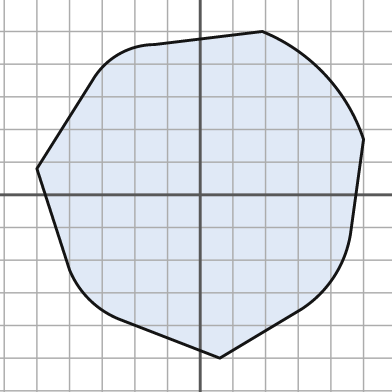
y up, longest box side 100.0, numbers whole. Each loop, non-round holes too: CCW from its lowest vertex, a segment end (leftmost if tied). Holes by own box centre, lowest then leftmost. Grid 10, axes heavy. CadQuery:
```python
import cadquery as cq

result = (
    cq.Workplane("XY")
    .moveTo(6.0, -50.0)
    .lineTo(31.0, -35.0)
    .threePointArc((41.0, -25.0), (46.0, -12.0))
    .lineTo(50.0, 17.0)
    .threePointArc((38.0, 37.0), (19.0, 50.0))
    .lineTo(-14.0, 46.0)
    .threePointArc((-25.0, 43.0), (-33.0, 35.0))
    .lineTo(-50.0, 8.0)
    .lineTo(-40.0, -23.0)
    .threePointArc((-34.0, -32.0), (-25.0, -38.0))
    .close()
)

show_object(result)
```